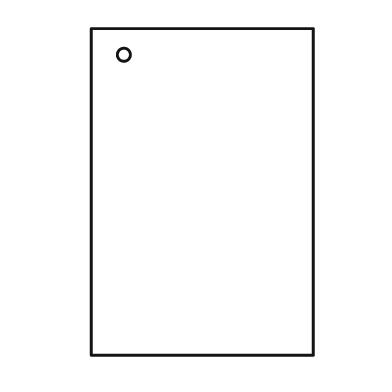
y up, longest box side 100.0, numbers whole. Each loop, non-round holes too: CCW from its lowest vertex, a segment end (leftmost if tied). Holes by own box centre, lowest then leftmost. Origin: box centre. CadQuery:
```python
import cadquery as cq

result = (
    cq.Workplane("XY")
    .moveTo(-34.0, -50.0)
    .lineTo(34.0, -50.0)
    .lineTo(34.0, 50.0)
    .lineTo(-34.0, 50.0)
    .close()
    .moveTo(-24.0, 42.0)
    .circle(2.0)
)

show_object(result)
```